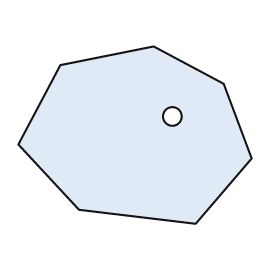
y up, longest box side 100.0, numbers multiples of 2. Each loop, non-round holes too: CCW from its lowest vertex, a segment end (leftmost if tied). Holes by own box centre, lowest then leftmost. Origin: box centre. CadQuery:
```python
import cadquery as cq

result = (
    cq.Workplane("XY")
    .moveTo(26.0, -38.0)
    .lineTo(50.0, -10.0)
    .lineTo(38.0, 22.0)
    .lineTo(8.0, 38.0)
    .lineTo(-32.0, 30.0)
    .lineTo(-50.0, -4.0)
    .lineTo(-24.0, -32.0)
    .close()
    .moveTo(16.0, 8.0)
    .circle(4.0)
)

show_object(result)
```